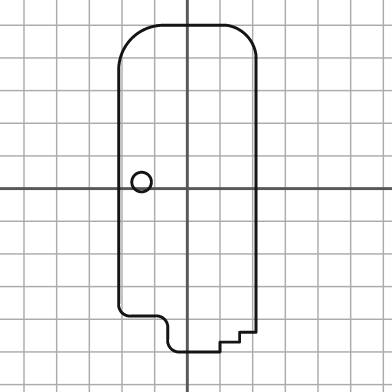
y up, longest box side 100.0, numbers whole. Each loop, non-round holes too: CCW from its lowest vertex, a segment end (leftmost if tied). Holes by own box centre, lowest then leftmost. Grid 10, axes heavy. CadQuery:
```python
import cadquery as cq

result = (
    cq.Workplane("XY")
    .moveTo(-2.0, -50.0)
    .lineTo(10.0, -50.0)
    .lineTo(10.0, -47.0)
    .lineTo(16.0, -47.0)
    .lineTo(16.0, -44.0)
    .lineTo(21.0, -44.0)
    .lineTo(21.0, 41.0)
    .threePointArc((18.0, 47.0), (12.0, 50.0))
    .lineTo(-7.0, 50.0)
    .threePointArc((-17.0, 46.0), (-21.0, 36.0))
    .lineTo(-21.0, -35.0)
    .threePointArc((-20.0, -38.0), (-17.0, -39.0))
    .lineTo(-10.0, -39.0)
    .threePointArc((-7.0, -40.0), (-6.0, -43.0))
    .lineTo(-6.0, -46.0)
    .threePointArc((-5.0, -49.0), (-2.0, -50.0))
    .close()
    .moveTo(-14.0, 2.0)
    .circle(3.0)
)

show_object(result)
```